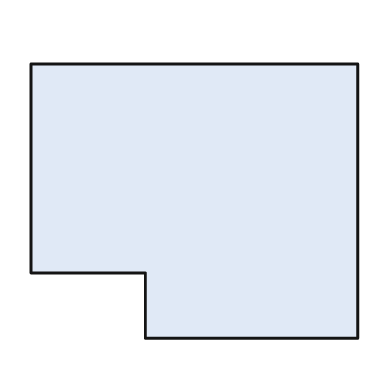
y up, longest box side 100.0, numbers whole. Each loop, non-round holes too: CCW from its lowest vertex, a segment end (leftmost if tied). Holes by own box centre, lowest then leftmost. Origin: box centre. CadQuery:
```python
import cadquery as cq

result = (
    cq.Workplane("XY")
    .moveTo(-15.0, -42.0)
    .lineTo(50.0, -42.0)
    .lineTo(50.0, 42.0)
    .lineTo(-50.0, 42.0)
    .lineTo(-50.0, -22.0)
    .lineTo(-15.0, -22.0)
    .close()
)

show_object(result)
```